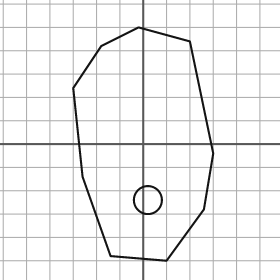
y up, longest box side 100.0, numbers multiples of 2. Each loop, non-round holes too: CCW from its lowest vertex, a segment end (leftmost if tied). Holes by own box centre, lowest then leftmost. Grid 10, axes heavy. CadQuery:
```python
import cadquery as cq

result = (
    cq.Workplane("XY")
    .moveTo(10.0, -50.0)
    .lineTo(26.0, -28.0)
    .lineTo(30.0, -4.0)
    .lineTo(20.0, 44.0)
    .lineTo(-2.0, 50.0)
    .lineTo(-18.0, 42.0)
    .lineTo(-30.0, 24.0)
    .lineTo(-26.0, -14.0)
    .lineTo(-14.0, -48.0)
    .close()
    .moveTo(2.0, -24.0)
    .circle(6.0)
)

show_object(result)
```